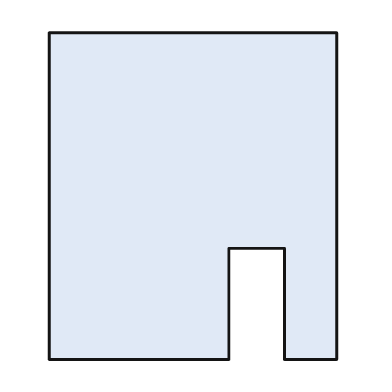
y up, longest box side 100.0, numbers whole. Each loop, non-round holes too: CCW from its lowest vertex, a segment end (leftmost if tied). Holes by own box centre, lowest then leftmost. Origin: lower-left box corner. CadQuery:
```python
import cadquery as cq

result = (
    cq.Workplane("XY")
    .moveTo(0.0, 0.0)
    .lineTo(55.0, 0.0)
    .lineTo(55.0, 34.0)
    .lineTo(72.0, 34.0)
    .lineTo(72.0, 0.0)
    .lineTo(88.0, 0.0)
    .lineTo(88.0, 100.0)
    .lineTo(0.0, 100.0)
    .close()
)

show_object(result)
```